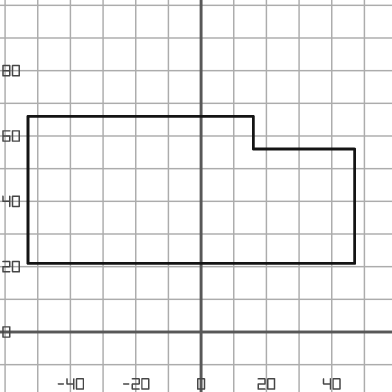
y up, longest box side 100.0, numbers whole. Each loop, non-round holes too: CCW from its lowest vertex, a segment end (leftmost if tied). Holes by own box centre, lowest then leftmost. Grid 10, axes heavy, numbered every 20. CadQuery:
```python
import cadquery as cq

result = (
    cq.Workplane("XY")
    .moveTo(-53.0, 21.0)
    .lineTo(47.0, 21.0)
    .lineTo(47.0, 56.0)
    .lineTo(16.0, 56.0)
    .lineTo(16.0, 66.0)
    .lineTo(-53.0, 66.0)
    .close()
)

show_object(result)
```